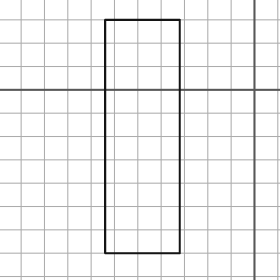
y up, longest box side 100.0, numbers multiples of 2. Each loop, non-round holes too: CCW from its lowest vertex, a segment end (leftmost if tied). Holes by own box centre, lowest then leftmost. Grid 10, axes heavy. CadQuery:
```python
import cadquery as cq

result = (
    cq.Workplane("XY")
    .moveTo(-64.0, -70.0)
    .lineTo(-32.0, -70.0)
    .lineTo(-32.0, 30.0)
    .lineTo(-64.0, 30.0)
    .close()
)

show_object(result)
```